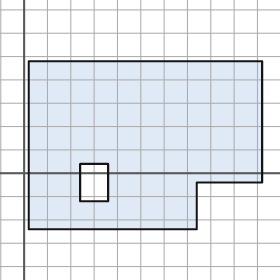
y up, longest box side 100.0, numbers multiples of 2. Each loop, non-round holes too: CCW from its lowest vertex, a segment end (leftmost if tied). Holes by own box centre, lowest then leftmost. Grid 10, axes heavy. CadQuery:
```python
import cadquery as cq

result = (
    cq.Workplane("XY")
    .moveTo(2.0, -24.0)
    .lineTo(74.0, -24.0)
    .lineTo(74.0, -4.0)
    .lineTo(102.0, -4.0)
    .lineTo(102.0, 48.0)
    .lineTo(2.0, 48.0)
    .close()
    .moveTo(24.0, -12.0)
    .lineTo(36.0, -12.0)
    .lineTo(36.0, 4.0)
    .lineTo(24.0, 4.0)
    .close()
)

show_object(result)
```